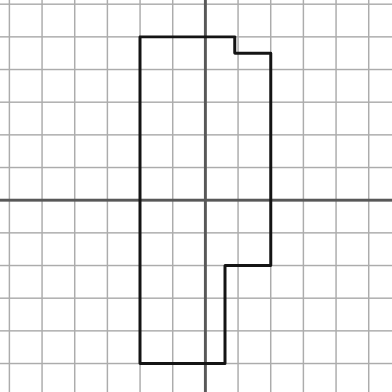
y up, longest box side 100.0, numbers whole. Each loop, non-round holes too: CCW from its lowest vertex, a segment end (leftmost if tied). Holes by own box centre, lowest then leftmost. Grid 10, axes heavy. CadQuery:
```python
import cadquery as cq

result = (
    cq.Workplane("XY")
    .moveTo(-20.0, -50.0)
    .lineTo(6.0, -50.0)
    .lineTo(6.0, -20.0)
    .lineTo(20.0, -20.0)
    .lineTo(20.0, 45.0)
    .lineTo(9.0, 45.0)
    .lineTo(9.0, 50.0)
    .lineTo(-20.0, 50.0)
    .close()
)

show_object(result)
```